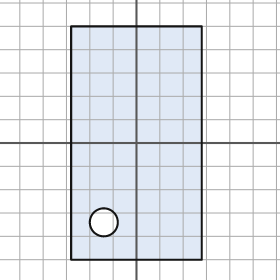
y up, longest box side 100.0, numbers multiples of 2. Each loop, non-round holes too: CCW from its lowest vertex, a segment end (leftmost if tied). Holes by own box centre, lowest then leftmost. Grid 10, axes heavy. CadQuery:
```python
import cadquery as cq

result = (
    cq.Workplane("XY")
    .moveTo(-28.0, -50.0)
    .lineTo(28.0, -50.0)
    .lineTo(28.0, 50.0)
    .lineTo(-28.0, 50.0)
    .close()
    .moveTo(-14.0, -34.0)
    .circle(6.0)
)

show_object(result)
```